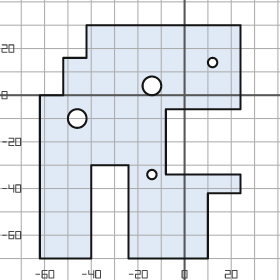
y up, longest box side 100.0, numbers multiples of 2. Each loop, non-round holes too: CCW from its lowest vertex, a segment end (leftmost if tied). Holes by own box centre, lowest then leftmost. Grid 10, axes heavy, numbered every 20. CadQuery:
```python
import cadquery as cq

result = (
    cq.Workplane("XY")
    .moveTo(-62.0, -70.0)
    .lineTo(-40.0, -70.0)
    .lineTo(-40.0, -30.0)
    .lineTo(-24.0, -30.0)
    .lineTo(-24.0, -70.0)
    .lineTo(10.0, -70.0)
    .lineTo(10.0, -42.0)
    .lineTo(24.0, -42.0)
    .lineTo(24.0, -34.0)
    .lineTo(-8.0, -34.0)
    .lineTo(-8.0, -6.0)
    .lineTo(24.0, -6.0)
    .lineTo(24.0, 30.0)
    .lineTo(-42.0, 30.0)
    .lineTo(-42.0, 16.0)
    .lineTo(-52.0, 16.0)
    .lineTo(-52.0, 0.0)
    .lineTo(-62.0, 0.0)
    .close()
    .moveTo(-14.0, -34.0)
    .circle(2.0)
    .moveTo(-46.0, -10.0)
    .circle(4.0)
    .moveTo(-14.0, 4.0)
    .circle(4.0)
    .moveTo(12.0, 14.0)
    .circle(2.0)
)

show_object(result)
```